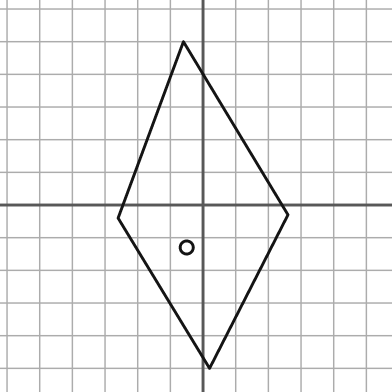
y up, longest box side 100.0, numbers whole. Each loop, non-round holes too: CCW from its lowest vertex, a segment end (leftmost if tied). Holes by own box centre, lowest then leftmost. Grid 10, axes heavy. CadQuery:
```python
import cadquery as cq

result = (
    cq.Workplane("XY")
    .moveTo(2.0, -50.0)
    .lineTo(26.0, -3.0)
    .lineTo(-6.0, 50.0)
    .lineTo(-26.0, -4.0)
    .close()
    .moveTo(-5.0, -13.0)
    .circle(2.0)
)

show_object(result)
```